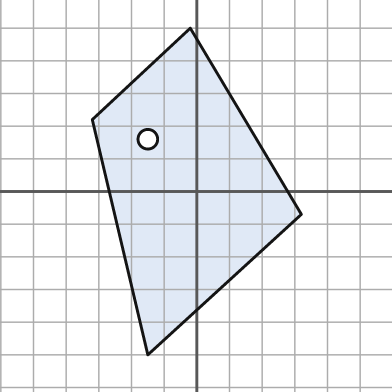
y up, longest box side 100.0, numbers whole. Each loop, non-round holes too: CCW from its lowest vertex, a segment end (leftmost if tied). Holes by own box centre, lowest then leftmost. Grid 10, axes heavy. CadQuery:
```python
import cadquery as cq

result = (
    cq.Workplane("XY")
    .moveTo(-15.0, -50.0)
    .lineTo(32.0, -7.0)
    .lineTo(-2.0, 50.0)
    .lineTo(-32.0, 22.0)
    .close()
    .moveTo(-15.0, 16.0)
    .circle(3.0)
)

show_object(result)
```